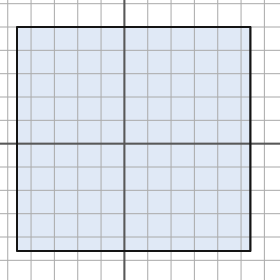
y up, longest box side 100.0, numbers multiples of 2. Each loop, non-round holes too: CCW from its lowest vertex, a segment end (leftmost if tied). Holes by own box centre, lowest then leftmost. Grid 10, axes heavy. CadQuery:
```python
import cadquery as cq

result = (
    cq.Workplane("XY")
    .moveTo(-46.0, -46.0)
    .lineTo(54.0, -46.0)
    .lineTo(54.0, 50.0)
    .lineTo(-46.0, 50.0)
    .close()
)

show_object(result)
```